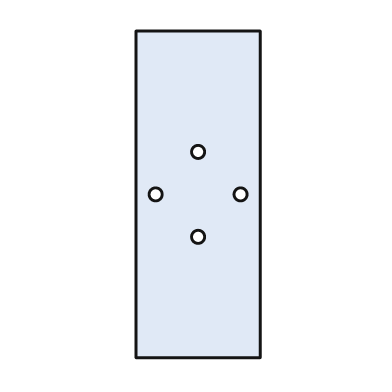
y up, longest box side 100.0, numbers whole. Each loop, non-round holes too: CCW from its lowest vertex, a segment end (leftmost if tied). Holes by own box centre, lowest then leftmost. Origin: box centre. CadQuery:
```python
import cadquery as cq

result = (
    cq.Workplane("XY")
    .moveTo(-19.0, -50.0)
    .lineTo(19.0, -50.0)
    .lineTo(19.0, 50.0)
    .lineTo(-19.0, 50.0)
    .close()
    .moveTo(0.0, -13.0)
    .circle(2.0)
    .moveTo(-13.0, 0.0)
    .circle(2.0)
    .moveTo(13.0, 0.0)
    .circle(2.0)
    .moveTo(0.0, 13.0)
    .circle(2.0)
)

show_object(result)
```